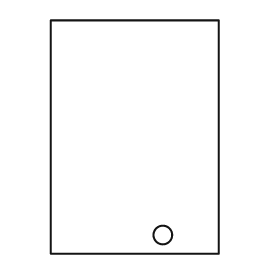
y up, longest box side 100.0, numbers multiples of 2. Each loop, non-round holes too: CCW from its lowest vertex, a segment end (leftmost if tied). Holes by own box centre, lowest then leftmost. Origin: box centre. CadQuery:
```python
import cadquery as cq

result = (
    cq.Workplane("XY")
    .moveTo(-36.0, -50.0)
    .lineTo(36.0, -50.0)
    .lineTo(36.0, 50.0)
    .lineTo(-36.0, 50.0)
    .close()
    .moveTo(12.0, -42.0)
    .circle(4.0)
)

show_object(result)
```